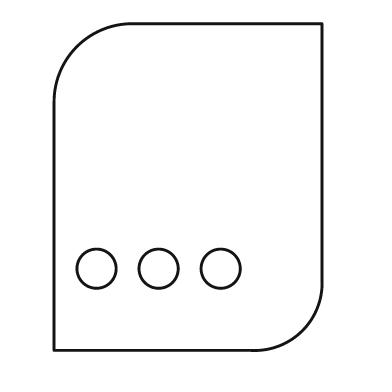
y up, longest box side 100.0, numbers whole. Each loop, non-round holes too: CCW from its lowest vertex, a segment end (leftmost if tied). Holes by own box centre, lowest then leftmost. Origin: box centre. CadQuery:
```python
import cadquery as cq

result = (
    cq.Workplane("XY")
    .moveTo(-41.0, -50.0)
    .lineTo(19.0, -50.0)
    .threePointArc((35.0, -44.0), (41.0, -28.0))
    .lineTo(41.0, 50.0)
    .lineTo(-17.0, 50.0)
    .threePointArc((-34.0, 43.0), (-41.0, 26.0))
    .close()
    .moveTo(-28.0, -25.0)
    .circle(6.0)
    .moveTo(-9.0, -25.0)
    .circle(6.0)
    .moveTo(10.0, -25.0)
    .circle(6.0)
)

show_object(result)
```